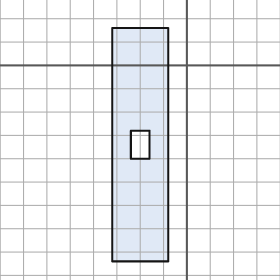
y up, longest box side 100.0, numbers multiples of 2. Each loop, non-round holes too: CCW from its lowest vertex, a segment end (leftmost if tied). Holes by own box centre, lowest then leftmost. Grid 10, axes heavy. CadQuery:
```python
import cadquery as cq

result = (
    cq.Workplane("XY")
    .moveTo(-32.0, -84.0)
    .lineTo(-8.0, -84.0)
    .lineTo(-8.0, 16.0)
    .lineTo(-32.0, 16.0)
    .close()
    .moveTo(-24.0, -40.0)
    .lineTo(-16.0, -40.0)
    .lineTo(-16.0, -28.0)
    .lineTo(-24.0, -28.0)
    .close()
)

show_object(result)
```